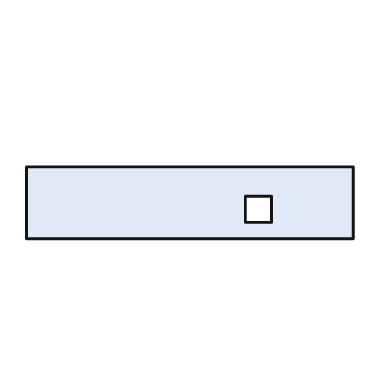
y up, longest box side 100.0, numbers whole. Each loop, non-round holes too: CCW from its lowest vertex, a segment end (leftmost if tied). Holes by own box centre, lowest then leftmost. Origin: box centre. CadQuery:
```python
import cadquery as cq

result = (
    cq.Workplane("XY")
    .moveTo(-50.0, -11.0)
    .lineTo(50.0, -11.0)
    .lineTo(50.0, 11.0)
    .lineTo(-50.0, 11.0)
    .close()
    .moveTo(17.0, -6.0)
    .lineTo(25.0, -6.0)
    .lineTo(25.0, 2.0)
    .lineTo(17.0, 2.0)
    .close()
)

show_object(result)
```